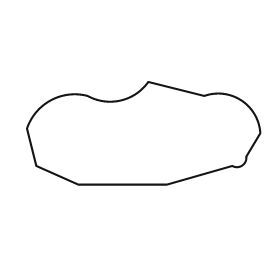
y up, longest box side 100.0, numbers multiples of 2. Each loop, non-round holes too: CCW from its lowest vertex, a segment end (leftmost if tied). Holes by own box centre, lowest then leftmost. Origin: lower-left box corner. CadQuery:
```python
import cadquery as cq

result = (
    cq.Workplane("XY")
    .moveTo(22.0, 0.0)
    .lineTo(60.0, 0.0)
    .lineTo(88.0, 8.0)
    .threePointArc((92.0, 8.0), (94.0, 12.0))
    .lineTo(100.0, 22.0)
    .threePointArc((92.0, 36.0), (76.0, 38.0))
    .lineTo(52.0, 44.0)
    .threePointArc((40.0, 36.0), (26.0, 38.0))
    .threePointArc((10.0, 36.0), (0.0, 24.0))
    .lineTo(4.0, 8.0)
    .close()
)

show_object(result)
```